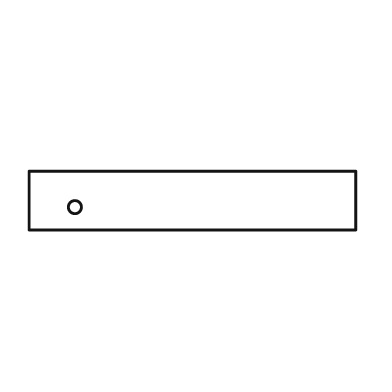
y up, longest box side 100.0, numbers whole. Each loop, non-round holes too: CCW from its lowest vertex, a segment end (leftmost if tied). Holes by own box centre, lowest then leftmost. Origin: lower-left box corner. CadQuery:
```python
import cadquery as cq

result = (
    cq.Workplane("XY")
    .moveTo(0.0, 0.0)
    .lineTo(100.0, 0.0)
    .lineTo(100.0, 18.0)
    .lineTo(0.0, 18.0)
    .close()
    .moveTo(14.0, 7.0)
    .circle(2.0)
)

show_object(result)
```